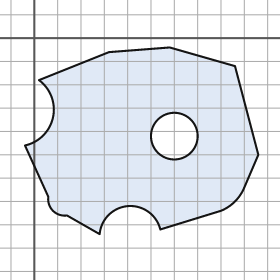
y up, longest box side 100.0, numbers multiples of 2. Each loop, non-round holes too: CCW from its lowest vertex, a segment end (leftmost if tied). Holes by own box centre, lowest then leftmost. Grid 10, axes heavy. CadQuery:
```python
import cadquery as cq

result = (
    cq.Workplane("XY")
    .moveTo(28.0, -84.0)
    .threePointArc((40.0, -72.0), (54.0, -82.0))
    .lineTo(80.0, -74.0)
    .threePointArc((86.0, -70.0), (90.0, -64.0))
    .lineTo(96.0, -50.0)
    .lineTo(86.0, -12.0)
    .lineTo(58.0, -4.0)
    .lineTo(32.0, -6.0)
    .lineTo(2.0, -18.0)
    .threePointArc((8.0, -34.0), (-4.0, -46.0))
    .lineTo(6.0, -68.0)
    .threePointArc((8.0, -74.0), (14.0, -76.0))
    .close()
    .moveTo(60.0, -42.0)
    .circle(10.0)
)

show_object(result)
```